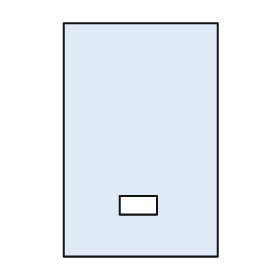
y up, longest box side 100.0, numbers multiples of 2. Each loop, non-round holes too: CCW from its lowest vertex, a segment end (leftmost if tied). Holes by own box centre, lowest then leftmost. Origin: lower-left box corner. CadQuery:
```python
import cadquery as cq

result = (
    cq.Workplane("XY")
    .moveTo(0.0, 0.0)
    .lineTo(66.0, 0.0)
    .lineTo(66.0, 100.0)
    .lineTo(0.0, 100.0)
    .close()
    .moveTo(24.0, 18.0)
    .lineTo(40.0, 18.0)
    .lineTo(40.0, 26.0)
    .lineTo(24.0, 26.0)
    .close()
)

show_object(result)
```